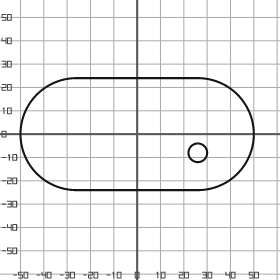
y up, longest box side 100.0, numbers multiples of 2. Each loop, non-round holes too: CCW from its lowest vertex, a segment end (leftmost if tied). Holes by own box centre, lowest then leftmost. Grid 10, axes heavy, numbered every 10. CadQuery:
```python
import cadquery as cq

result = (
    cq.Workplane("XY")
    .moveTo(-26.0, -24.0)
    .lineTo(26.0, -24.0)
    .threePointArc((50.0, 0.0), (26.0, 24.0))
    .lineTo(-26.0, 24.0)
    .threePointArc((-50.0, 0.0), (-26.0, -24.0))
    .close()
    .moveTo(26.0, -8.0)
    .circle(4.0)
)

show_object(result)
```